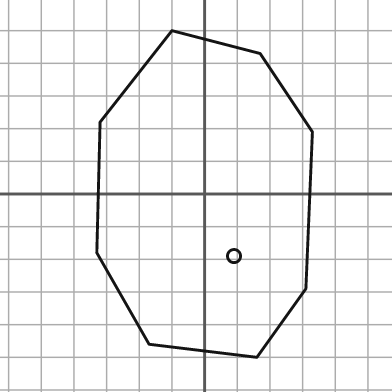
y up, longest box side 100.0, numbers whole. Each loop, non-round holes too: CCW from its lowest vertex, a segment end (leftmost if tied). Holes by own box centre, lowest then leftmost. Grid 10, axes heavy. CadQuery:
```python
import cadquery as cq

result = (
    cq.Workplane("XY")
    .moveTo(16.0, -50.0)
    .lineTo(31.0, -29.0)
    .lineTo(33.0, 19.0)
    .lineTo(17.0, 43.0)
    .lineTo(-10.0, 50.0)
    .lineTo(-32.0, 22.0)
    .lineTo(-33.0, -18.0)
    .lineTo(-17.0, -46.0)
    .close()
    .moveTo(9.0, -19.0)
    .circle(2.0)
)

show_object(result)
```